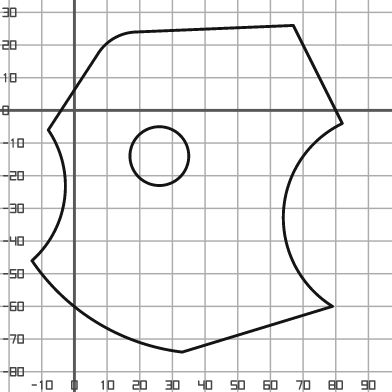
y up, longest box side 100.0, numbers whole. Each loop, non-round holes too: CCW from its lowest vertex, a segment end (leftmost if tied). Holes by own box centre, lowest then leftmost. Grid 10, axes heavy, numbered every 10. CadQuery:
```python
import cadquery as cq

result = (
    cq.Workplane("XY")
    .moveTo(33.0, -74.0)
    .lineTo(79.0, -60.0)
    .threePointArc((64.0, -31.0), (82.0, -4.0))
    .lineTo(67.0, 26.0)
    .lineTo(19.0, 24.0)
    .threePointArc((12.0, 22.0), (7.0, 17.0))
    .lineTo(-8.0, -6.0)
    .threePointArc((-3.0, -27.0), (-13.0, -46.0))
    .threePointArc((7.0, -65.0), (33.0, -74.0))
    .close()
    .moveTo(26.0, -14.0)
    .circle(9.0)
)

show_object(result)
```